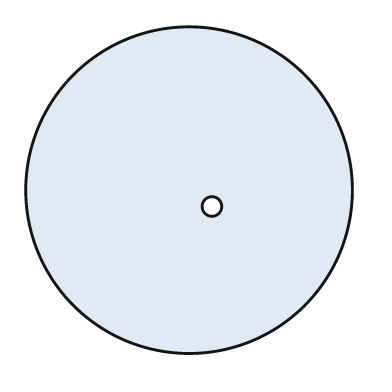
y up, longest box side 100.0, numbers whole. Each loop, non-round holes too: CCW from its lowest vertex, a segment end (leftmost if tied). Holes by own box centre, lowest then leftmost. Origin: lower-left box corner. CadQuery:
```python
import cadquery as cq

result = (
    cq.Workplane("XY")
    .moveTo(50.0, 50.0)
    .circle(50.0)
    .moveTo(57.0, 45.0)
    .circle(3.0)
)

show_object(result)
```